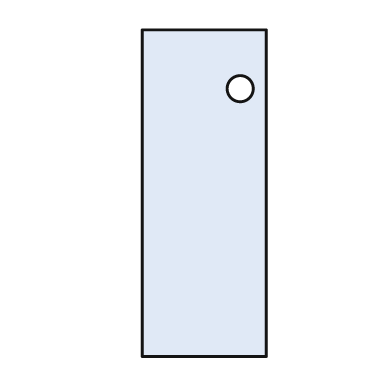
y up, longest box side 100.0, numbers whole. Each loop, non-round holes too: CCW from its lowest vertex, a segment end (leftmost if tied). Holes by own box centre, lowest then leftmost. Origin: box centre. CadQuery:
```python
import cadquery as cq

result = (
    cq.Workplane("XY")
    .moveTo(-19.0, -50.0)
    .lineTo(19.0, -50.0)
    .lineTo(19.0, 50.0)
    .lineTo(-19.0, 50.0)
    .close()
    .moveTo(11.0, 32.0)
    .circle(4.0)
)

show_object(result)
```